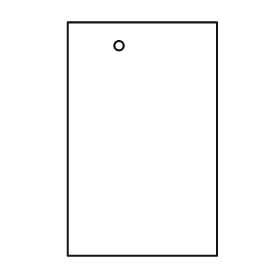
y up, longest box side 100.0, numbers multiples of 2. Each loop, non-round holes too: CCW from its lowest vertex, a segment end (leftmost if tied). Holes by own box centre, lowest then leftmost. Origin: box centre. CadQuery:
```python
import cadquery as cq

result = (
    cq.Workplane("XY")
    .moveTo(-32.0, -50.0)
    .lineTo(32.0, -50.0)
    .lineTo(32.0, 50.0)
    .lineTo(-32.0, 50.0)
    .close()
    .moveTo(-10.0, 40.0)
    .circle(2.0)
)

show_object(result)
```